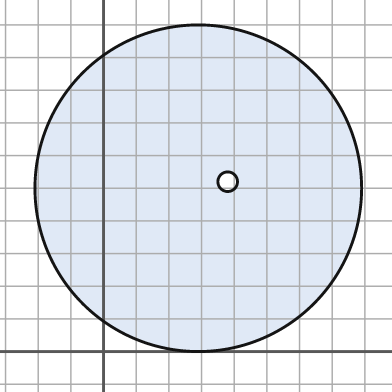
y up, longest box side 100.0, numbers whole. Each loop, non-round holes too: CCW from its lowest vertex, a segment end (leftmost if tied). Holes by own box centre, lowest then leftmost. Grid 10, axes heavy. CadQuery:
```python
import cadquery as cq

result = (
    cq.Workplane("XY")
    .moveTo(29.0, 50.0)
    .circle(50.0)
    .moveTo(38.0, 52.0)
    .circle(3.0)
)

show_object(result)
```